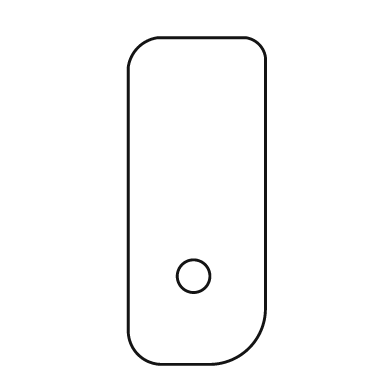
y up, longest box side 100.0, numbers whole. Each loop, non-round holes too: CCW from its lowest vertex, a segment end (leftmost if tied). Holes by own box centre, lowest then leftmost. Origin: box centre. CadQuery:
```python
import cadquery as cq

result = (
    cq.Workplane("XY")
    .moveTo(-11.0, -50.0)
    .lineTo(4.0, -50.0)
    .threePointArc((16.0, -45.0), (21.0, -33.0))
    .lineTo(21.0, 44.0)
    .threePointArc((19.0, 48.0), (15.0, 50.0))
    .lineTo(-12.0, 50.0)
    .threePointArc((-18.0, 47.0), (-21.0, 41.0))
    .lineTo(-21.0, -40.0)
    .threePointArc((-18.0, -47.0), (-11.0, -50.0))
    .close()
    .moveTo(-1.0, -23.0)
    .circle(5.0)
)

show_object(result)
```